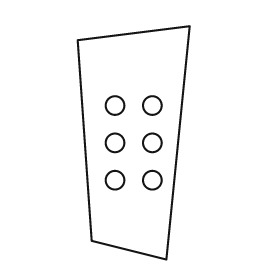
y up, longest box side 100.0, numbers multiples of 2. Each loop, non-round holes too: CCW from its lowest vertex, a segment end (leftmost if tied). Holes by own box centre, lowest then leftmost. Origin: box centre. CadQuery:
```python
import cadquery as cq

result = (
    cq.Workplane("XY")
    .moveTo(14.0, -50.0)
    .lineTo(24.0, 50.0)
    .lineTo(-24.0, 44.0)
    .lineTo(-18.0, -42.0)
    .close()
    .moveTo(-8.0, -16.0)
    .circle(4.0)
    .moveTo(8.0, -16.0)
    .circle(4.0)
    .moveTo(-8.0, 0.0)
    .circle(4.0)
    .moveTo(8.0, 0.0)
    .circle(4.0)
    .moveTo(-8.0, 16.0)
    .circle(4.0)
    .moveTo(8.0, 16.0)
    .circle(4.0)
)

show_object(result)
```